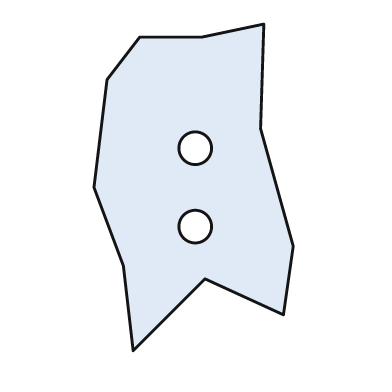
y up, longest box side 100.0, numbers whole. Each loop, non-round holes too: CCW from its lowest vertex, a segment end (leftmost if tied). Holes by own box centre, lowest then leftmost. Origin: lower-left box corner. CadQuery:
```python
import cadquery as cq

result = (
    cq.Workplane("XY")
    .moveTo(12.0, 0.0)
    .lineTo(34.0, 22.0)
    .lineTo(58.0, 11.0)
    .lineTo(61.0, 32.0)
    .lineTo(51.0, 68.0)
    .lineTo(52.0, 100.0)
    .lineTo(33.0, 96.0)
    .lineTo(14.0, 96.0)
    .lineTo(4.0, 83.0)
    .lineTo(0.0, 50.0)
    .lineTo(9.0, 26.0)
    .close()
    .moveTo(31.0, 38.0)
    .circle(5.0)
    .moveTo(31.0, 62.0)
    .circle(5.0)
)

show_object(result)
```